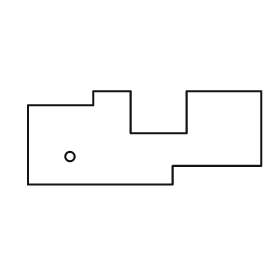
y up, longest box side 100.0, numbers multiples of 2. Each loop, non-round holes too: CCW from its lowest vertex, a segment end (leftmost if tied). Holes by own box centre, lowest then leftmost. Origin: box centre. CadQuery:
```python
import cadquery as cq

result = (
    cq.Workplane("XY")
    .moveTo(-50.0, -20.0)
    .lineTo(12.0, -20.0)
    .lineTo(12.0, -12.0)
    .lineTo(50.0, -12.0)
    .lineTo(50.0, 20.0)
    .lineTo(18.0, 20.0)
    .lineTo(18.0, 2.0)
    .lineTo(-6.0, 2.0)
    .lineTo(-6.0, 20.0)
    .lineTo(-22.0, 20.0)
    .lineTo(-22.0, 14.0)
    .lineTo(-50.0, 14.0)
    .close()
    .moveTo(-32.0, -8.0)
    .circle(2.0)
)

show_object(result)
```